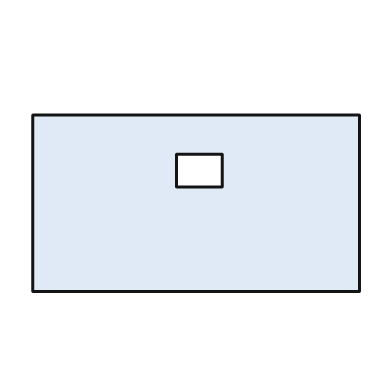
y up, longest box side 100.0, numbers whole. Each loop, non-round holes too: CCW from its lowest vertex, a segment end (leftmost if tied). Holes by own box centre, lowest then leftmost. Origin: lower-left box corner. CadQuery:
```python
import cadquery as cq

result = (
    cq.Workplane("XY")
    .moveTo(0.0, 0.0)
    .lineTo(100.0, 0.0)
    .lineTo(100.0, 54.0)
    .lineTo(0.0, 54.0)
    .close()
    .moveTo(44.0, 32.0)
    .lineTo(58.0, 32.0)
    .lineTo(58.0, 42.0)
    .lineTo(44.0, 42.0)
    .close()
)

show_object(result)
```